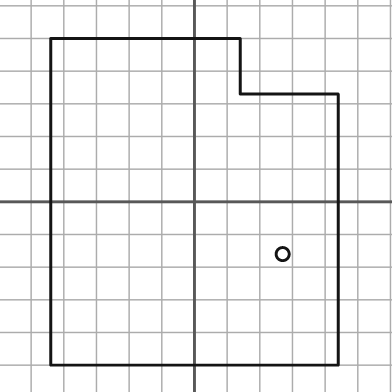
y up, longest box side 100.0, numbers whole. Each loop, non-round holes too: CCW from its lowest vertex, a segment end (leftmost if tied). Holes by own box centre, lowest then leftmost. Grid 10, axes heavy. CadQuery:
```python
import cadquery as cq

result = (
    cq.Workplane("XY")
    .moveTo(-44.0, -50.0)
    .lineTo(44.0, -50.0)
    .lineTo(44.0, 33.0)
    .lineTo(14.0, 33.0)
    .lineTo(14.0, 50.0)
    .lineTo(-44.0, 50.0)
    .close()
    .moveTo(27.0, -16.0)
    .circle(2.0)
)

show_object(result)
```